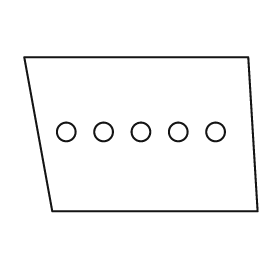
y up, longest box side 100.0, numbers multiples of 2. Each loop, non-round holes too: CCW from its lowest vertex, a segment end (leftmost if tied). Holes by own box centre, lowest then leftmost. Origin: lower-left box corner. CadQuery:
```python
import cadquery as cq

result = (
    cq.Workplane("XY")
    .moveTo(12.0, 0.0)
    .lineTo(100.0, 0.0)
    .lineTo(96.0, 66.0)
    .lineTo(0.0, 66.0)
    .close()
    .moveTo(18.0, 34.0)
    .circle(4.0)
    .moveTo(34.0, 34.0)
    .circle(4.0)
    .moveTo(50.0, 34.0)
    .circle(4.0)
    .moveTo(66.0, 34.0)
    .circle(4.0)
    .moveTo(82.0, 34.0)
    .circle(4.0)
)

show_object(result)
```